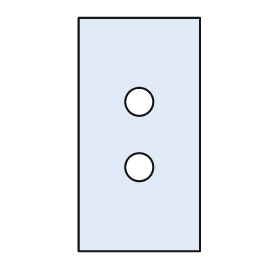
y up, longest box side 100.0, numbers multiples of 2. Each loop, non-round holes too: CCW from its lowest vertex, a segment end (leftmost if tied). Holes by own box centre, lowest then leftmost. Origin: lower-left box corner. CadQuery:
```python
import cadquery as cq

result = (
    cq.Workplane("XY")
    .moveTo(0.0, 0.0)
    .lineTo(52.0, 0.0)
    .lineTo(52.0, 100.0)
    .lineTo(0.0, 100.0)
    .close()
    .moveTo(26.0, 36.0)
    .circle(6.0)
    .moveTo(26.0, 64.0)
    .circle(6.0)
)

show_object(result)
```